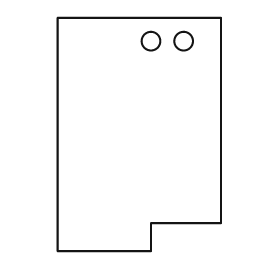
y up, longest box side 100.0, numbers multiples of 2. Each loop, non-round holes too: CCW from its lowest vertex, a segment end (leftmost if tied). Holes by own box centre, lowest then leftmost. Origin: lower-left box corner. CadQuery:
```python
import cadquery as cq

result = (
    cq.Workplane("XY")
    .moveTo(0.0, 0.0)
    .lineTo(40.0, 0.0)
    .lineTo(40.0, 12.0)
    .lineTo(70.0, 12.0)
    .lineTo(70.0, 100.0)
    .lineTo(0.0, 100.0)
    .close()
    .moveTo(40.0, 90.0)
    .circle(4.0)
    .moveTo(54.0, 90.0)
    .circle(4.0)
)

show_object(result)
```